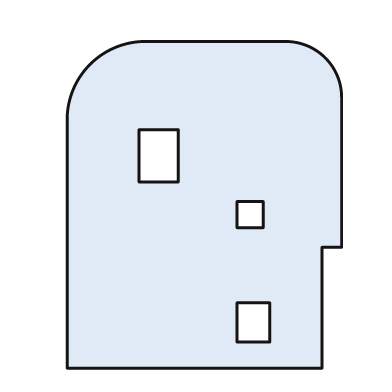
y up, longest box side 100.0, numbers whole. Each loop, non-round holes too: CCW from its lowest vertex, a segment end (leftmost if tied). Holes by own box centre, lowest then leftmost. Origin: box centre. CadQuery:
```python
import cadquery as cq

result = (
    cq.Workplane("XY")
    .moveTo(-42.0, -50.0)
    .lineTo(36.0, -50.0)
    .lineTo(36.0, -13.0)
    .lineTo(42.0, -13.0)
    .lineTo(42.0, 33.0)
    .threePointArc((37.0, 45.0), (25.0, 50.0))
    .lineTo(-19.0, 50.0)
    .threePointArc((-35.0, 43.0), (-42.0, 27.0))
    .close()
    .moveTo(10.0, -42.0)
    .lineTo(20.0, -42.0)
    .lineTo(20.0, -30.0)
    .lineTo(10.0, -30.0)
    .close()
    .moveTo(10.0, -7.0)
    .lineTo(18.0, -7.0)
    .lineTo(18.0, 1.0)
    .lineTo(10.0, 1.0)
    .close()
    .moveTo(-20.0, 7.0)
    .lineTo(-8.0, 7.0)
    .lineTo(-8.0, 23.0)
    .lineTo(-20.0, 23.0)
    .close()
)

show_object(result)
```